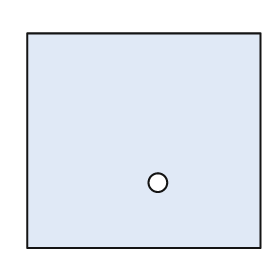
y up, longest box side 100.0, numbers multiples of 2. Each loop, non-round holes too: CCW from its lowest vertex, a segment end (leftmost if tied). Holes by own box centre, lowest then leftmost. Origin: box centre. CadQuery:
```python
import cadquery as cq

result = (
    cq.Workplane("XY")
    .moveTo(-50.0, -46.0)
    .lineTo(50.0, -46.0)
    .lineTo(50.0, 46.0)
    .lineTo(-50.0, 46.0)
    .close()
    .moveTo(6.0, -18.0)
    .circle(4.0)
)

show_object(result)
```